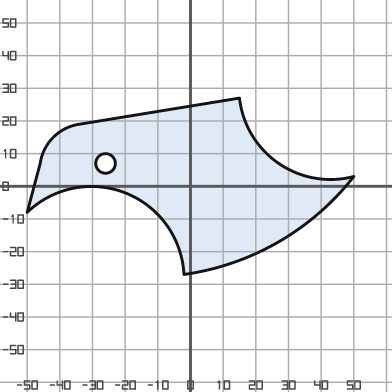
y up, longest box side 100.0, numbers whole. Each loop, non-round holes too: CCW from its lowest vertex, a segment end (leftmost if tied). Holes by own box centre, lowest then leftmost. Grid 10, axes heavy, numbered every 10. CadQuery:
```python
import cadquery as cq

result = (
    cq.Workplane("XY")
    .moveTo(-2.0, -27.0)
    .threePointArc((27.0, -17.0), (50.0, 3.0))
    .threePointArc((27.0, 7.0), (15.0, 27.0))
    .lineTo(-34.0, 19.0)
    .threePointArc((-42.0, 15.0), (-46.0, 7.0))
    .lineTo(-50.0, -8.0)
    .threePointArc((-20.0, -2.0), (-2.0, -27.0))
    .close()
    .moveTo(-26.0, 7.0)
    .circle(3.0)
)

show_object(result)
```